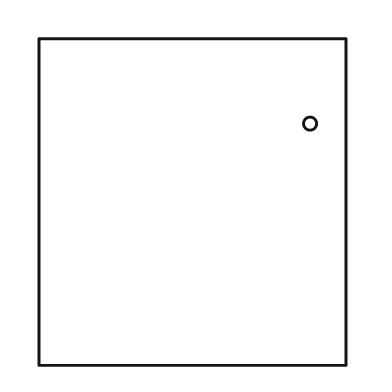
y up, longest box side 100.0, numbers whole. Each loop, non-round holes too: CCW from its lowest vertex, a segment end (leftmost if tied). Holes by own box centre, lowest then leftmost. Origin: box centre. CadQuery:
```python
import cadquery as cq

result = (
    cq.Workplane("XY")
    .moveTo(-47.0, -50.0)
    .lineTo(47.0, -50.0)
    .lineTo(47.0, 50.0)
    .lineTo(-47.0, 50.0)
    .close()
    .moveTo(36.0, 24.0)
    .circle(2.0)
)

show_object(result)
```